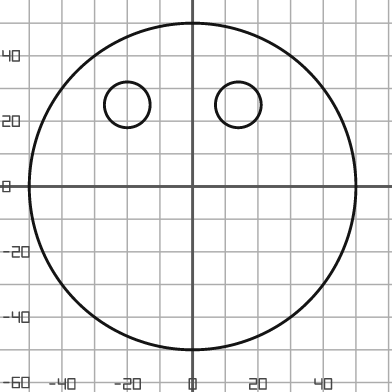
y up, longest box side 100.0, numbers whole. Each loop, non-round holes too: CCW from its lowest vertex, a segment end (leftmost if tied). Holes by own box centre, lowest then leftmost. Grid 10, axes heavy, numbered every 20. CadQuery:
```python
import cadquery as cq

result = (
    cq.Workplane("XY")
    .moveTo(0.0, 0.0)
    .circle(50.0)
    .moveTo(-20.0, 25.0)
    .circle(7.0)
    .moveTo(14.0, 25.0)
    .circle(7.0)
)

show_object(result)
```